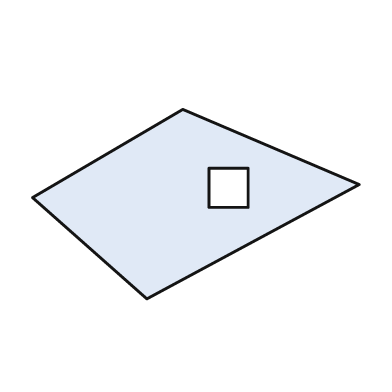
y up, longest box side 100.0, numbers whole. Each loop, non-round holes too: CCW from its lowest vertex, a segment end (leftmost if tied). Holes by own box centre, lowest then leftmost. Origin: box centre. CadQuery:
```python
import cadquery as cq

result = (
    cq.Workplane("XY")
    .moveTo(-15.0, -29.0)
    .lineTo(50.0, 6.0)
    .lineTo(-4.0, 29.0)
    .lineTo(-50.0, 2.0)
    .close()
    .moveTo(4.0, -1.0)
    .lineTo(16.0, -1.0)
    .lineTo(16.0, 11.0)
    .lineTo(4.0, 11.0)
    .close()
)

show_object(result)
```